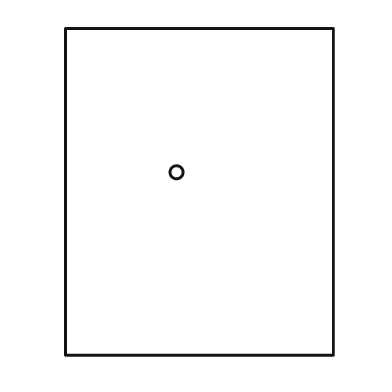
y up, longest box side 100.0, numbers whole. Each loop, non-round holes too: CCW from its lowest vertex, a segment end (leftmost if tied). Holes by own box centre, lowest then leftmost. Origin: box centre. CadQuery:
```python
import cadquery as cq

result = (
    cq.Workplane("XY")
    .moveTo(-41.0, -50.0)
    .lineTo(41.0, -50.0)
    .lineTo(41.0, 50.0)
    .lineTo(-41.0, 50.0)
    .close()
    .moveTo(-7.0, 6.0)
    .circle(2.0)
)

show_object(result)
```